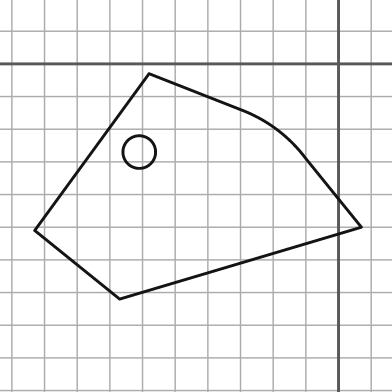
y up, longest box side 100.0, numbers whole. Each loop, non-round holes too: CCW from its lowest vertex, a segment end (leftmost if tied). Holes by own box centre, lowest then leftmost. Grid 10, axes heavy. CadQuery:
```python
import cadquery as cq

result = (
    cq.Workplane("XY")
    .moveTo(-67.0, -72.0)
    .lineTo(7.0, -50.0)
    .lineTo(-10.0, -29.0)
    .threePointArc((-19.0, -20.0), (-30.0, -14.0))
    .lineTo(-58.0, -3.0)
    .lineTo(-93.0, -51.0)
    .close()
    .moveTo(-61.0, -27.0)
    .circle(5.0)
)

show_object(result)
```